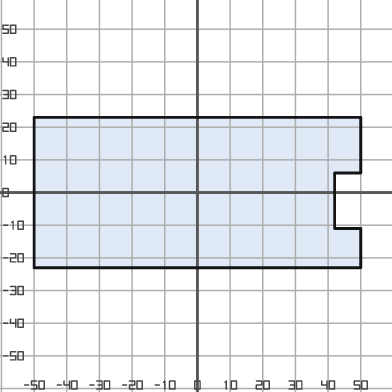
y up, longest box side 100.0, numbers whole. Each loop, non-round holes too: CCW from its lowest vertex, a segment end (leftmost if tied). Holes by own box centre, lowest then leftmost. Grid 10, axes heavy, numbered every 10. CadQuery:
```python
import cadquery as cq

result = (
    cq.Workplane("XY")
    .moveTo(-50.0, -23.0)
    .lineTo(50.0, -23.0)
    .lineTo(50.0, -11.0)
    .lineTo(42.0, -11.0)
    .lineTo(42.0, 6.0)
    .lineTo(50.0, 6.0)
    .lineTo(50.0, 23.0)
    .lineTo(-50.0, 23.0)
    .close()
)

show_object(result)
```